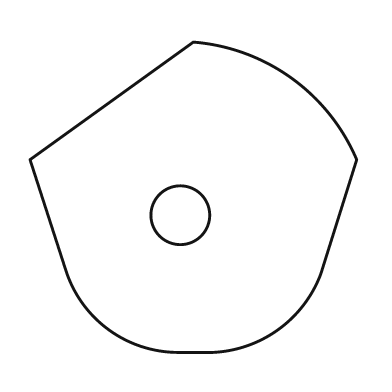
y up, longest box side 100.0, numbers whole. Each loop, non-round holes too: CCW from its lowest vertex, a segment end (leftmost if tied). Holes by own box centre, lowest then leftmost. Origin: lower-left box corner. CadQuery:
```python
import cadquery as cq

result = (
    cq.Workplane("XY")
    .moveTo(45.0, 0.0)
    .lineTo(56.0, 0.0)
    .threePointArc((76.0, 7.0), (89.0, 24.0))
    .lineTo(100.0, 59.0)
    .threePointArc((80.0, 84.0), (50.0, 95.0))
    .lineTo(0.0, 59.0)
    .lineTo(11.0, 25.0)
    .threePointArc((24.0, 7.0), (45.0, 0.0))
    .close()
    .moveTo(46.0, 42.0)
    .circle(9.0)
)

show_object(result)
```